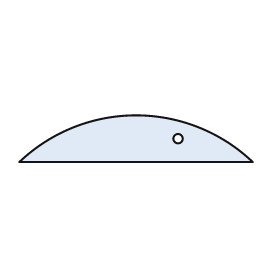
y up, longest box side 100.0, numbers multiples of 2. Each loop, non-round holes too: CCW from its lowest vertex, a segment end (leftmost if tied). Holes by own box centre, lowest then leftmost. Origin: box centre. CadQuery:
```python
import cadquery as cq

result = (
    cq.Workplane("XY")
    .moveTo(-50.0, -10.0)
    .lineTo(50.0, -10.0)
    .threePointArc((0.0, 10.0), (-50.0, -10.0))
    .close()
    .moveTo(18.0, 0.0)
    .circle(2.0)
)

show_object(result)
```